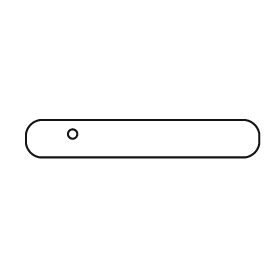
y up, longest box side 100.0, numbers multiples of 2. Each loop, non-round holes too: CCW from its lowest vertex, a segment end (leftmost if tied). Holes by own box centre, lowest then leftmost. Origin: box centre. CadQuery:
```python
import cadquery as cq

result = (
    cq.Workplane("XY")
    .moveTo(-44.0, -8.0)
    .lineTo(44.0, -8.0)
    .threePointArc((48.0, -6.0), (50.0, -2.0))
    .lineTo(50.0, 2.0)
    .threePointArc((48.0, 6.0), (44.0, 8.0))
    .lineTo(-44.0, 8.0)
    .threePointArc((-48.0, 6.0), (-50.0, 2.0))
    .lineTo(-50.0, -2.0)
    .threePointArc((-48.0, -6.0), (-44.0, -8.0))
    .close()
    .moveTo(-30.0, 2.0)
    .circle(2.0)
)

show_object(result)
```